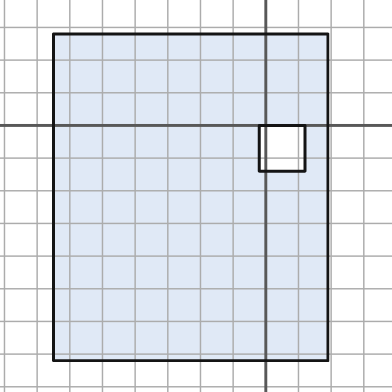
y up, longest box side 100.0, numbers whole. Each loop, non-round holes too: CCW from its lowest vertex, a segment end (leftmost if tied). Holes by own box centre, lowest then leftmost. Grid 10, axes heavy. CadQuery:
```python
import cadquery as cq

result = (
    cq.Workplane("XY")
    .moveTo(-65.0, -72.0)
    .lineTo(19.0, -72.0)
    .lineTo(19.0, 28.0)
    .lineTo(-65.0, 28.0)
    .close()
    .moveTo(-2.0, -14.0)
    .lineTo(12.0, -14.0)
    .lineTo(12.0, 0.0)
    .lineTo(-2.0, 0.0)
    .close()
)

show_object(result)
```